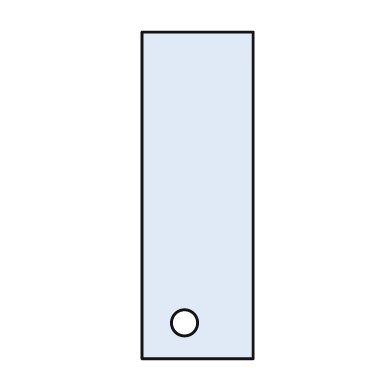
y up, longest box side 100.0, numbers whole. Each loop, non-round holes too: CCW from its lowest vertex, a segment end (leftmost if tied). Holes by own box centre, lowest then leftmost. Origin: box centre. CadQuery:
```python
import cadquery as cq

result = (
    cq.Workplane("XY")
    .moveTo(-17.0, -50.0)
    .lineTo(17.0, -50.0)
    .lineTo(17.0, 50.0)
    .lineTo(-17.0, 50.0)
    .close()
    .moveTo(-4.0, -39.0)
    .circle(4.0)
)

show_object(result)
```